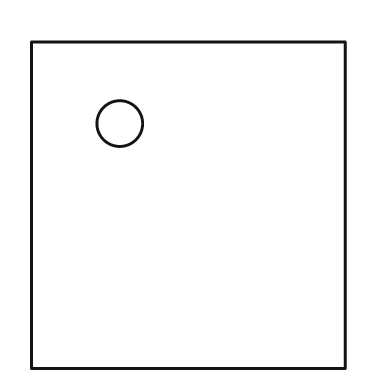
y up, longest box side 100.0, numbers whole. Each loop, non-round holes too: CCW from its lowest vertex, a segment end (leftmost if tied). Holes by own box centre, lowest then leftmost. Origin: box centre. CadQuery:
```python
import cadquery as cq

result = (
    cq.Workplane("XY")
    .moveTo(-48.0, -50.0)
    .lineTo(48.0, -50.0)
    .lineTo(48.0, 50.0)
    .lineTo(-48.0, 50.0)
    .close()
    .moveTo(-21.0, 25.0)
    .circle(7.0)
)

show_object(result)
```